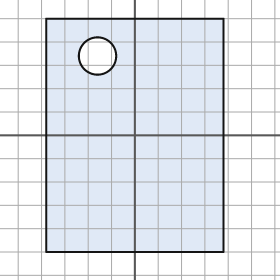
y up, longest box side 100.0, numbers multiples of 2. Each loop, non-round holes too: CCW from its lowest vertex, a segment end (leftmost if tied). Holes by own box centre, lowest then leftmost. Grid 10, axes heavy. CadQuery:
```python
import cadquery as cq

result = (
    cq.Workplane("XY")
    .moveTo(-38.0, -50.0)
    .lineTo(38.0, -50.0)
    .lineTo(38.0, 50.0)
    .lineTo(-38.0, 50.0)
    .close()
    .moveTo(-16.0, 34.0)
    .circle(8.0)
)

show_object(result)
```